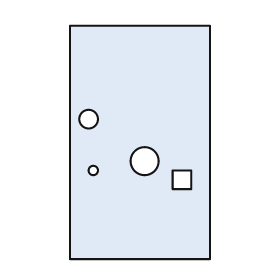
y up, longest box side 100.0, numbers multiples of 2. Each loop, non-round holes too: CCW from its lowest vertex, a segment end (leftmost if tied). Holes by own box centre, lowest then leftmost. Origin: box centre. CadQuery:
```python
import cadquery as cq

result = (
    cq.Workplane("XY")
    .moveTo(-30.0, -50.0)
    .lineTo(30.0, -50.0)
    .lineTo(30.0, 50.0)
    .lineTo(-30.0, 50.0)
    .close()
    .moveTo(14.0, -20.0)
    .lineTo(22.0, -20.0)
    .lineTo(22.0, -12.0)
    .lineTo(14.0, -12.0)
    .close()
    .moveTo(-20.0, -12.0)
    .circle(2.0)
    .moveTo(2.0, -8.0)
    .circle(6.0)
    .moveTo(-22.0, 10.0)
    .circle(4.0)
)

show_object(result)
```